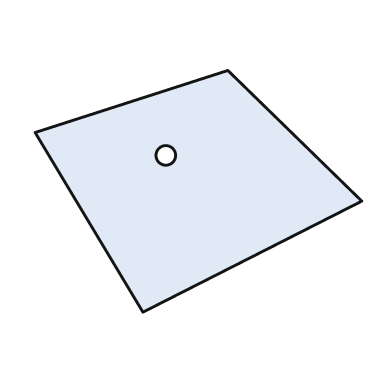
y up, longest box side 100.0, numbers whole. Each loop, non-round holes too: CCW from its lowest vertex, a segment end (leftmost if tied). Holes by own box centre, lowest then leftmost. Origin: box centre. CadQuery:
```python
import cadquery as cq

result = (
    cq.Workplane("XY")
    .moveTo(-17.0, -37.0)
    .lineTo(50.0, -3.0)
    .lineTo(9.0, 37.0)
    .lineTo(-50.0, 18.0)
    .close()
    .moveTo(-10.0, 11.0)
    .circle(3.0)
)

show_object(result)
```